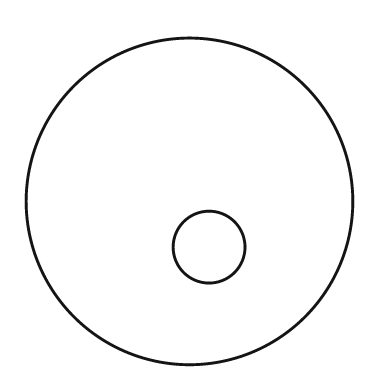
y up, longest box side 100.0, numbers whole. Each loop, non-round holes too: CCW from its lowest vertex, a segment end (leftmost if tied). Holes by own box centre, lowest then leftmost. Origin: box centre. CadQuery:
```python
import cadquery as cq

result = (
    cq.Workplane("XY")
    .moveTo(0.0, 0.0)
    .circle(50.0)
    .moveTo(6.0, -14.0)
    .circle(11.0)
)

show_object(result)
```